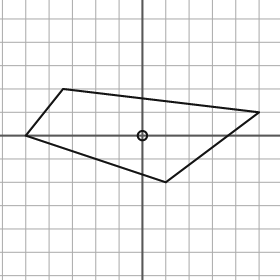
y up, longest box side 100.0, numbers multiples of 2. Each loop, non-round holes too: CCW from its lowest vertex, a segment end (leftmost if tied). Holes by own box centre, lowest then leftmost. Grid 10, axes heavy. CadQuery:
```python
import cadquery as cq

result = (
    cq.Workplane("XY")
    .moveTo(10.0, -20.0)
    .lineTo(50.0, 10.0)
    .lineTo(-34.0, 20.0)
    .lineTo(-50.0, 0.0)
    .close()
    .moveTo(0.0, 0.0)
    .circle(2.0)
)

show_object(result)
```